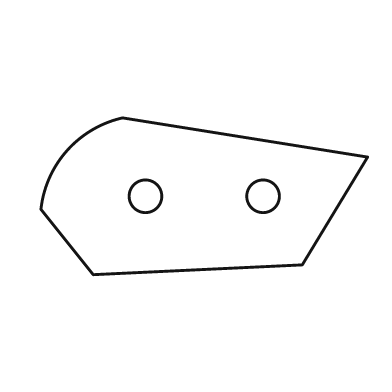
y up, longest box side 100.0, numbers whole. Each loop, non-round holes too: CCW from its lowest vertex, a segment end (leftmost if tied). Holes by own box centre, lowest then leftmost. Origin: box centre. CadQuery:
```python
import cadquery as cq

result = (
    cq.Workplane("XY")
    .moveTo(-34.0, -24.0)
    .lineTo(30.0, -21.0)
    .lineTo(50.0, 12.0)
    .lineTo(-25.0, 24.0)
    .threePointArc((-42.0, 14.0), (-50.0, -4.0))
    .close()
    .moveTo(-18.0, 0.0)
    .circle(5.0)
    .moveTo(18.0, 0.0)
    .circle(5.0)
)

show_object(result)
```